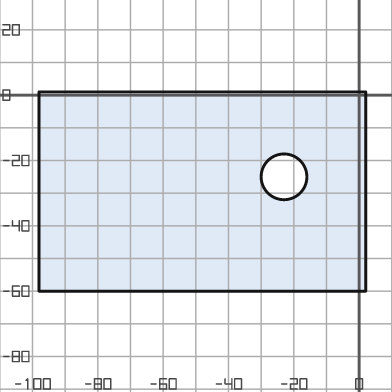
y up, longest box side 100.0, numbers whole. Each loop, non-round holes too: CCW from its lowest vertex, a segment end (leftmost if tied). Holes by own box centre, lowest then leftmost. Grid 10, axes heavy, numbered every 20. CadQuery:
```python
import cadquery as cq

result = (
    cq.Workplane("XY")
    .moveTo(-98.0, -60.0)
    .lineTo(2.0, -60.0)
    .lineTo(2.0, 1.0)
    .lineTo(-98.0, 1.0)
    .close()
    .moveTo(-23.0, -25.0)
    .circle(7.0)
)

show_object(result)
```